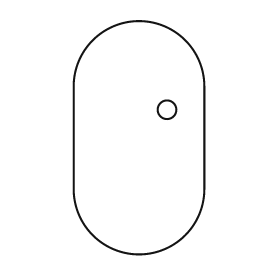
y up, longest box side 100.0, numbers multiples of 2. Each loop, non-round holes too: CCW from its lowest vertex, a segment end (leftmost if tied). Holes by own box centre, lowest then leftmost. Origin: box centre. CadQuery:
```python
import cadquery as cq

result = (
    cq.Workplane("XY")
    .moveTo(-28.0, -22.0)
    .threePointArc((0.0, -50.0), (28.0, -22.0))
    .lineTo(28.0, 22.0)
    .threePointArc((0.0, 50.0), (-28.0, 22.0))
    .close()
    .moveTo(12.0, 12.0)
    .circle(4.0)
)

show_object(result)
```